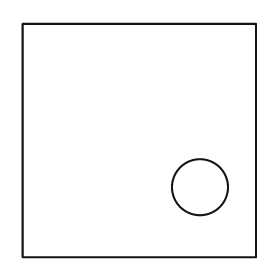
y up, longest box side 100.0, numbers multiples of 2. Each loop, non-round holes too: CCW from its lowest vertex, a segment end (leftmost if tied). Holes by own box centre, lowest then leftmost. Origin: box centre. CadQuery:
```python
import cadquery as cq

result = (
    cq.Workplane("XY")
    .moveTo(-50.0, -50.0)
    .lineTo(50.0, -50.0)
    .lineTo(50.0, 50.0)
    .lineTo(-50.0, 50.0)
    .close()
    .moveTo(26.0, -20.0)
    .circle(12.0)
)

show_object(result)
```